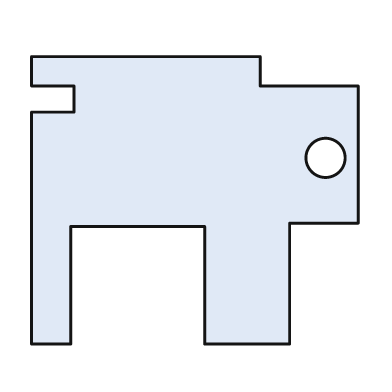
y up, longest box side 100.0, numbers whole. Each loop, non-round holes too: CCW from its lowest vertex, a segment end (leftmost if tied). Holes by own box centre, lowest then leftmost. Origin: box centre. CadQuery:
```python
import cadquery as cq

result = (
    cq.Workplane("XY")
    .moveTo(-50.0, -44.0)
    .lineTo(-38.0, -44.0)
    .lineTo(-38.0, -8.0)
    .lineTo(3.0, -8.0)
    .lineTo(3.0, -44.0)
    .lineTo(29.0, -44.0)
    .lineTo(29.0, -7.0)
    .lineTo(50.0, -7.0)
    .lineTo(50.0, 35.0)
    .lineTo(20.0, 35.0)
    .lineTo(20.0, 44.0)
    .lineTo(-50.0, 44.0)
    .lineTo(-50.0, 35.0)
    .lineTo(-37.0, 35.0)
    .lineTo(-37.0, 27.0)
    .lineTo(-50.0, 27.0)
    .close()
    .moveTo(40.0, 13.0)
    .circle(6.0)
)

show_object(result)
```